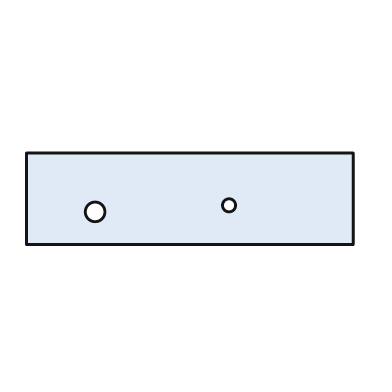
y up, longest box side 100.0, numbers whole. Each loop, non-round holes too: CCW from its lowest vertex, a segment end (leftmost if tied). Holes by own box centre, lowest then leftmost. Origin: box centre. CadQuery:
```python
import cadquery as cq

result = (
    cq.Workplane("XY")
    .moveTo(-50.0, -14.0)
    .lineTo(50.0, -14.0)
    .lineTo(50.0, 14.0)
    .lineTo(-50.0, 14.0)
    .close()
    .moveTo(-29.0, -4.0)
    .circle(3.0)
    .moveTo(12.0, -2.0)
    .circle(2.0)
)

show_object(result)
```